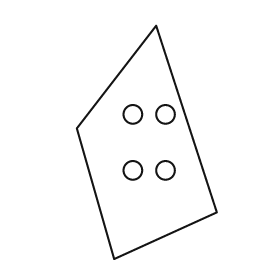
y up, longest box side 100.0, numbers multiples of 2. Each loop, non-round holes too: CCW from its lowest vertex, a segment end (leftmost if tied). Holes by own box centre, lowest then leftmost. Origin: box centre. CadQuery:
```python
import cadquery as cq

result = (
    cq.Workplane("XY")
    .moveTo(-14.0, -50.0)
    .lineTo(30.0, -30.0)
    .lineTo(4.0, 50.0)
    .lineTo(-30.0, 6.0)
    .close()
    .moveTo(-6.0, -12.0)
    .circle(4.0)
    .moveTo(8.0, -12.0)
    .circle(4.0)
    .moveTo(-6.0, 12.0)
    .circle(4.0)
    .moveTo(8.0, 12.0)
    .circle(4.0)
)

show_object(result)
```